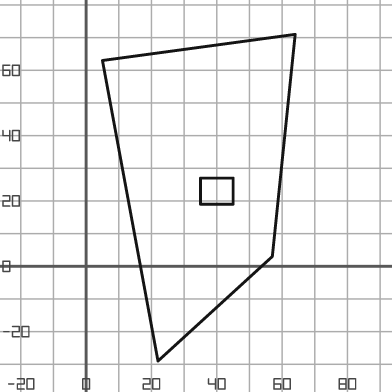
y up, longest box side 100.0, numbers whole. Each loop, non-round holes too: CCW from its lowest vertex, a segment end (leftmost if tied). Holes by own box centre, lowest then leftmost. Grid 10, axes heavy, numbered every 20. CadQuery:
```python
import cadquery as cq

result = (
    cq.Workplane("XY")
    .moveTo(22.0, -29.0)
    .lineTo(57.0, 3.0)
    .lineTo(64.0, 71.0)
    .lineTo(5.0, 63.0)
    .close()
    .moveTo(35.0, 19.0)
    .lineTo(45.0, 19.0)
    .lineTo(45.0, 27.0)
    .lineTo(35.0, 27.0)
    .close()
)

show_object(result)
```